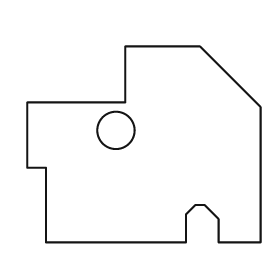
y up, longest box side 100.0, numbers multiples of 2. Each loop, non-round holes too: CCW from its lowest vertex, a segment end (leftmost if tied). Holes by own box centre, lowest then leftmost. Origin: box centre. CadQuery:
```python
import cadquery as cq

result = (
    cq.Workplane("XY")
    .moveTo(-42.0, -42.0)
    .lineTo(18.0, -42.0)
    .lineTo(18.0, -30.0)
    .lineTo(22.0, -26.0)
    .lineTo(26.0, -26.0)
    .lineTo(32.0, -32.0)
    .lineTo(32.0, -42.0)
    .lineTo(50.0, -42.0)
    .lineTo(50.0, 16.0)
    .lineTo(24.0, 42.0)
    .lineTo(-8.0, 42.0)
    .lineTo(-8.0, 18.0)
    .lineTo(-50.0, 18.0)
    .lineTo(-50.0, -10.0)
    .lineTo(-42.0, -10.0)
    .close()
    .moveTo(-12.0, 6.0)
    .circle(8.0)
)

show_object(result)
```